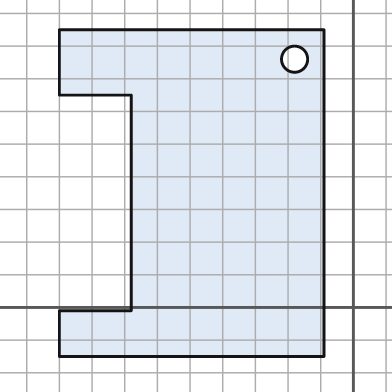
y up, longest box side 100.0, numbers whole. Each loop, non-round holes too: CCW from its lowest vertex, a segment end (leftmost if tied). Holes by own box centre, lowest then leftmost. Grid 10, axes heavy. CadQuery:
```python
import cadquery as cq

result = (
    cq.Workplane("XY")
    .moveTo(-90.0, -15.0)
    .lineTo(-9.0, -15.0)
    .lineTo(-9.0, 85.0)
    .lineTo(-90.0, 85.0)
    .lineTo(-90.0, 65.0)
    .lineTo(-68.0, 65.0)
    .lineTo(-68.0, -1.0)
    .lineTo(-90.0, -1.0)
    .close()
    .moveTo(-18.0, 76.0)
    .circle(4.0)
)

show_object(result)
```